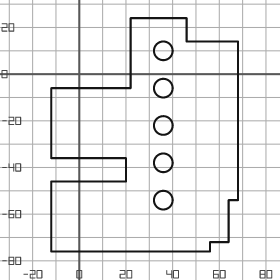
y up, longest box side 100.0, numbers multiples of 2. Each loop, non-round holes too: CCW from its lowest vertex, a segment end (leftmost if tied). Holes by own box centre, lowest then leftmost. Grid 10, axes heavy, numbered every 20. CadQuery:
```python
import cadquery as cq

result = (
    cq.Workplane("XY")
    .moveTo(-12.0, -76.0)
    .lineTo(56.0, -76.0)
    .lineTo(56.0, -72.0)
    .lineTo(64.0, -72.0)
    .lineTo(64.0, -54.0)
    .lineTo(68.0, -54.0)
    .lineTo(68.0, 14.0)
    .lineTo(46.0, 14.0)
    .lineTo(46.0, 24.0)
    .lineTo(22.0, 24.0)
    .lineTo(22.0, -6.0)
    .lineTo(-12.0, -6.0)
    .lineTo(-12.0, -36.0)
    .lineTo(20.0, -36.0)
    .lineTo(20.0, -46.0)
    .lineTo(-12.0, -46.0)
    .close()
    .moveTo(36.0, -54.0)
    .circle(4.0)
    .moveTo(36.0, -38.0)
    .circle(4.0)
    .moveTo(36.0, -22.0)
    .circle(4.0)
    .moveTo(36.0, -6.0)
    .circle(4.0)
    .moveTo(36.0, 10.0)
    .circle(4.0)
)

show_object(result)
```